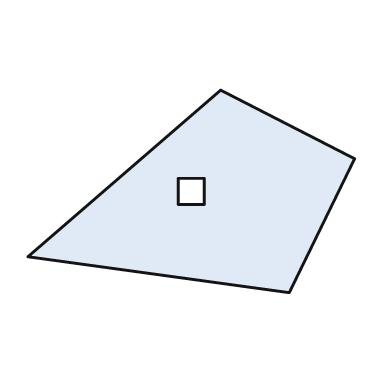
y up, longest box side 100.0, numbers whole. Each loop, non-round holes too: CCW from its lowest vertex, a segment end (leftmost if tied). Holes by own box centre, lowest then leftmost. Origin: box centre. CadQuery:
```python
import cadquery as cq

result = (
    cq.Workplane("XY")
    .moveTo(30.0, -31.0)
    .lineTo(50.0, 10.0)
    .lineTo(9.0, 31.0)
    .lineTo(-50.0, -20.0)
    .close()
    .moveTo(-4.0, -4.0)
    .lineTo(4.0, -4.0)
    .lineTo(4.0, 4.0)
    .lineTo(-4.0, 4.0)
    .close()
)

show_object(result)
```